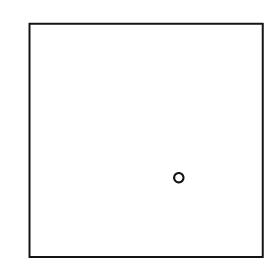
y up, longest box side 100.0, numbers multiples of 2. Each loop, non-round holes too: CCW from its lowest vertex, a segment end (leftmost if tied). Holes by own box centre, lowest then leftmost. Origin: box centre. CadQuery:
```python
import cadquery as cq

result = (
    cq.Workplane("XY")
    .moveTo(-50.0, -50.0)
    .lineTo(50.0, -50.0)
    .lineTo(50.0, 50.0)
    .lineTo(-50.0, 50.0)
    .close()
    .moveTo(14.0, -16.0)
    .circle(2.0)
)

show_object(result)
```